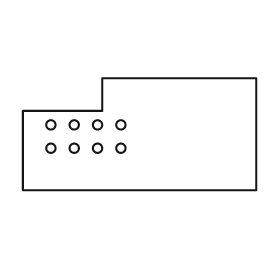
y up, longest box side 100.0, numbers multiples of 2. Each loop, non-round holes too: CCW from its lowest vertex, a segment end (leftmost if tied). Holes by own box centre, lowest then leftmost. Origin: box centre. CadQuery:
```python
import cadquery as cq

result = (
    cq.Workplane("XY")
    .moveTo(-50.0, -24.0)
    .lineTo(50.0, -24.0)
    .lineTo(50.0, 24.0)
    .lineTo(-16.0, 24.0)
    .lineTo(-16.0, 10.0)
    .lineTo(-50.0, 10.0)
    .close()
    .moveTo(-38.0, -6.0)
    .circle(2.0)
    .moveTo(-28.0, -6.0)
    .circle(2.0)
    .moveTo(-18.0, -6.0)
    .circle(2.0)
    .moveTo(-8.0, -6.0)
    .circle(2.0)
    .moveTo(-38.0, 4.0)
    .circle(2.0)
    .moveTo(-28.0, 4.0)
    .circle(2.0)
    .moveTo(-18.0, 4.0)
    .circle(2.0)
    .moveTo(-8.0, 4.0)
    .circle(2.0)
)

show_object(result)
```